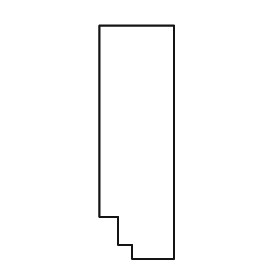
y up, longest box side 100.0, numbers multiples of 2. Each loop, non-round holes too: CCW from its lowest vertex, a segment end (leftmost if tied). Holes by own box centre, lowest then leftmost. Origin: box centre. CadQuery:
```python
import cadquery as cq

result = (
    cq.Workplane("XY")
    .moveTo(-2.0, -50.0)
    .lineTo(16.0, -50.0)
    .lineTo(16.0, 50.0)
    .lineTo(-16.0, 50.0)
    .lineTo(-16.0, -32.0)
    .lineTo(-8.0, -32.0)
    .lineTo(-8.0, -44.0)
    .lineTo(-2.0, -44.0)
    .close()
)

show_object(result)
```